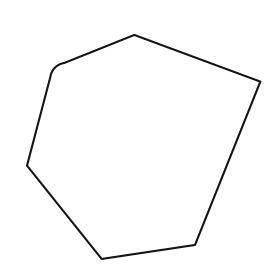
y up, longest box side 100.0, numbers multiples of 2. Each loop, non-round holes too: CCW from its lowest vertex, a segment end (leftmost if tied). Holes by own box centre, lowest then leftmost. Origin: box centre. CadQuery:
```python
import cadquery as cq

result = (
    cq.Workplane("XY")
    .moveTo(-18.0, -48.0)
    .lineTo(22.0, -42.0)
    .lineTo(50.0, 28.0)
    .lineTo(-4.0, 48.0)
    .lineTo(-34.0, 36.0)
    .threePointArc((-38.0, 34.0), (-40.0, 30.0))
    .lineTo(-50.0, -8.0)
    .close()
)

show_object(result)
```